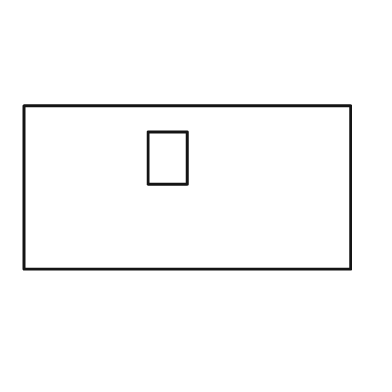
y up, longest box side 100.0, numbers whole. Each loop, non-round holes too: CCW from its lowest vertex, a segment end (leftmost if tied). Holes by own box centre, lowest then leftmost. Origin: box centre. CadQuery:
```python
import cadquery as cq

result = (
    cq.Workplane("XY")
    .moveTo(-50.0, -25.0)
    .lineTo(50.0, -25.0)
    .lineTo(50.0, 25.0)
    .lineTo(-50.0, 25.0)
    .close()
    .moveTo(-12.0, 1.0)
    .lineTo(0.0, 1.0)
    .lineTo(0.0, 17.0)
    .lineTo(-12.0, 17.0)
    .close()
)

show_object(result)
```